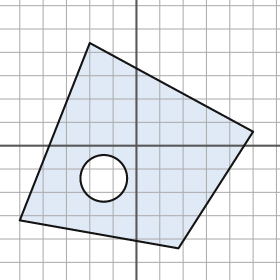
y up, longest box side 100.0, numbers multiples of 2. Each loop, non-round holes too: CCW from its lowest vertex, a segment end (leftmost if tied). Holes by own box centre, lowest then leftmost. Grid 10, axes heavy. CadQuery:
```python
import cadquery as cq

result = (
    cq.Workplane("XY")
    .moveTo(18.0, -44.0)
    .lineTo(50.0, 6.0)
    .lineTo(-20.0, 44.0)
    .lineTo(-50.0, -32.0)
    .close()
    .moveTo(-14.0, -14.0)
    .circle(10.0)
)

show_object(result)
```